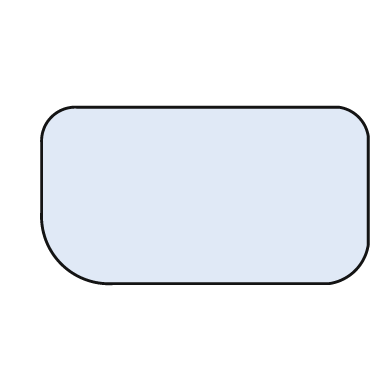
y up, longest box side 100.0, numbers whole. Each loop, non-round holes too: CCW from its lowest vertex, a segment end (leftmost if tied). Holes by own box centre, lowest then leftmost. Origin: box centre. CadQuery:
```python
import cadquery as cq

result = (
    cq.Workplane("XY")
    .moveTo(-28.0, -27.0)
    .lineTo(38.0, -27.0)
    .threePointArc((46.0, -23.0), (50.0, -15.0))
    .lineTo(50.0, 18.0)
    .threePointArc((47.0, 24.0), (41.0, 27.0))
    .lineTo(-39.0, 27.0)
    .threePointArc((-47.0, 24.0), (-50.0, 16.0))
    .lineTo(-50.0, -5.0)
    .threePointArc((-44.0, -21.0), (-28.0, -27.0))
    .close()
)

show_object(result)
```